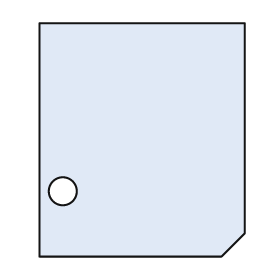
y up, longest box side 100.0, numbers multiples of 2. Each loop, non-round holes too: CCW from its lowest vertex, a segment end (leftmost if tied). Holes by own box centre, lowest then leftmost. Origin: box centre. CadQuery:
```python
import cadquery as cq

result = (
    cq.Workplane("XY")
    .moveTo(-44.0, -50.0)
    .lineTo(34.0, -50.0)
    .lineTo(44.0, -40.0)
    .lineTo(44.0, 50.0)
    .lineTo(-44.0, 50.0)
    .close()
    .moveTo(-34.0, -22.0)
    .circle(6.0)
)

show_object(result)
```